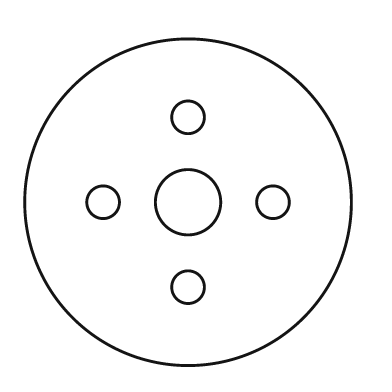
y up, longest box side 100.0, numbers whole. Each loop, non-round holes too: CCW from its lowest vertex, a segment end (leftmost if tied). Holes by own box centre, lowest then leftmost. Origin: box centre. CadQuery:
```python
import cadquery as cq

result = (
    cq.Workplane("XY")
    .moveTo(0.0, 0.0)
    .circle(50.0)
    .moveTo(0.0, -26.0)
    .circle(5.0)
    .moveTo(-26.0, 0.0)
    .circle(5.0)
    .moveTo(0.0, 0.0)
    .circle(10.0)
    .moveTo(26.0, 0.0)
    .circle(5.0)
    .moveTo(0.0, 26.0)
    .circle(5.0)
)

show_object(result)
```